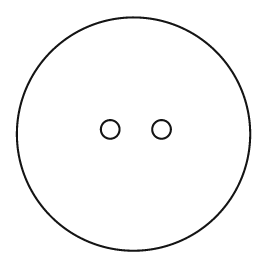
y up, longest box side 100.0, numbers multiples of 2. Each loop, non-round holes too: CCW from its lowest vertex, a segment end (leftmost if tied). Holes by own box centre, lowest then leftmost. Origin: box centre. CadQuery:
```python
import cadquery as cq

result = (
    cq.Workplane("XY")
    .moveTo(0.0, 0.0)
    .circle(50.0)
    .moveTo(-10.0, 2.0)
    .circle(4.0)
    .moveTo(12.0, 2.0)
    .circle(4.0)
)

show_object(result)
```